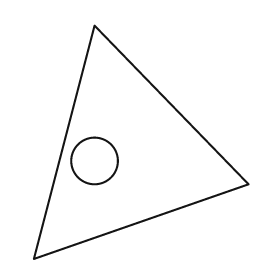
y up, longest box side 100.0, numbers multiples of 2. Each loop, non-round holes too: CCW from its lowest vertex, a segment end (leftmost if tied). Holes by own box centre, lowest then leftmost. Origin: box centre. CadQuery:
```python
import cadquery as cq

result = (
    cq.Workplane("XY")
    .moveTo(-46.0, -50.0)
    .lineTo(46.0, -18.0)
    .lineTo(-20.0, 50.0)
    .close()
    .moveTo(-20.0, -8.0)
    .circle(10.0)
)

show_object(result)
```